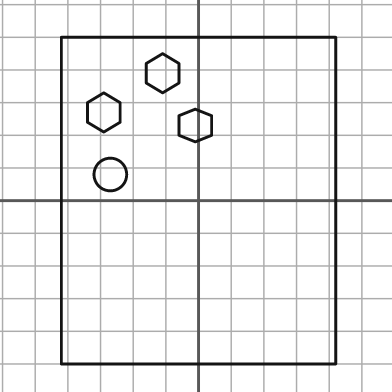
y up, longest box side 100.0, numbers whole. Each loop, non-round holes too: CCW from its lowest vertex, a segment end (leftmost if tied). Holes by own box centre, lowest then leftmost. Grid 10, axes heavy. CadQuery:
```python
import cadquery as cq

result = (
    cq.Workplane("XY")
    .moveTo(-42.0, -50.0)
    .lineTo(42.0, -50.0)
    .lineTo(42.0, 50.0)
    .lineTo(-42.0, 50.0)
    .close()
    .moveTo(-27.0, 8.0)
    .circle(5.0)
    .moveTo(-1.0, 18.0)
    .lineTo(4.0, 20.0)
    .lineTo(4.0, 26.0)
    .lineTo(-1.0, 28.0)
    .lineTo(-6.0, 26.0)
    .lineTo(-6.0, 20.0)
    .close()
    .moveTo(-29.0, 21.0)
    .lineTo(-24.0, 24.0)
    .lineTo(-24.0, 30.0)
    .lineTo(-29.0, 33.0)
    .lineTo(-34.0, 30.0)
    .lineTo(-34.0, 24.0)
    .close()
    .moveTo(-11.0, 33.0)
    .lineTo(-6.0, 36.0)
    .lineTo(-6.0, 42.0)
    .lineTo(-11.0, 45.0)
    .lineTo(-16.0, 42.0)
    .lineTo(-16.0, 36.0)
    .close()
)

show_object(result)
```